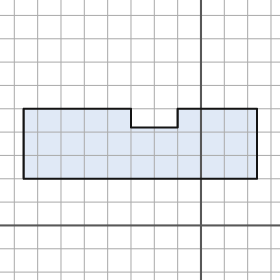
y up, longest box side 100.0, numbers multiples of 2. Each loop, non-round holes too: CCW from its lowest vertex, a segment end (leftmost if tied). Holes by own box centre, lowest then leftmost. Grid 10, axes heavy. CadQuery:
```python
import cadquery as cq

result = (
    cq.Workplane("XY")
    .moveTo(-76.0, 20.0)
    .lineTo(24.0, 20.0)
    .lineTo(24.0, 50.0)
    .lineTo(-10.0, 50.0)
    .lineTo(-10.0, 42.0)
    .lineTo(-30.0, 42.0)
    .lineTo(-30.0, 50.0)
    .lineTo(-76.0, 50.0)
    .close()
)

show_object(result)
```